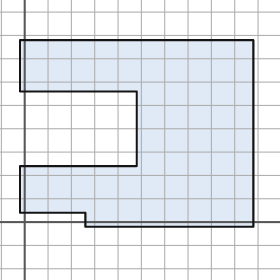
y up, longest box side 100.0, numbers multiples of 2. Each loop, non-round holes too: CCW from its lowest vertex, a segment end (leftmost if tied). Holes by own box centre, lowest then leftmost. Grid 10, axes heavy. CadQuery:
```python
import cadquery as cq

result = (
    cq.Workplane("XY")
    .moveTo(26.0, -2.0)
    .lineTo(98.0, -2.0)
    .lineTo(98.0, 78.0)
    .lineTo(-2.0, 78.0)
    .lineTo(-2.0, 56.0)
    .lineTo(48.0, 56.0)
    .lineTo(48.0, 24.0)
    .lineTo(-2.0, 24.0)
    .lineTo(-2.0, 4.0)
    .lineTo(26.0, 4.0)
    .close()
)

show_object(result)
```